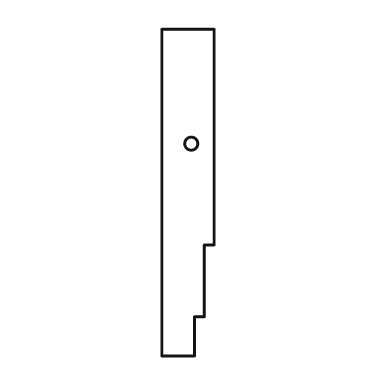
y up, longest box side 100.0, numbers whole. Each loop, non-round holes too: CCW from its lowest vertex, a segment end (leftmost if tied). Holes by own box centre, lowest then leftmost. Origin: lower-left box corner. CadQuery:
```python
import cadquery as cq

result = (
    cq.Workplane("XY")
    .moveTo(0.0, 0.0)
    .lineTo(10.0, 0.0)
    .lineTo(10.0, 12.0)
    .lineTo(13.0, 12.0)
    .lineTo(13.0, 34.0)
    .lineTo(16.0, 34.0)
    .lineTo(16.0, 100.0)
    .lineTo(0.0, 100.0)
    .close()
    .moveTo(9.0, 65.0)
    .circle(2.0)
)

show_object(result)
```